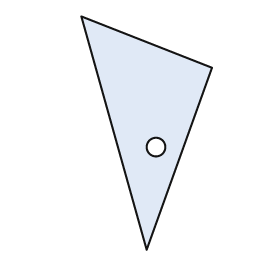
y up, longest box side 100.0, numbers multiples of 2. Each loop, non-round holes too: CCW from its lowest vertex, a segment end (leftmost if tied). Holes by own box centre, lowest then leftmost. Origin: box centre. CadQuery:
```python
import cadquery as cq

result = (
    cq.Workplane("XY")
    .moveTo(0.0, -50.0)
    .lineTo(28.0, 28.0)
    .lineTo(-28.0, 50.0)
    .close()
    .moveTo(4.0, -6.0)
    .circle(4.0)
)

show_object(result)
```